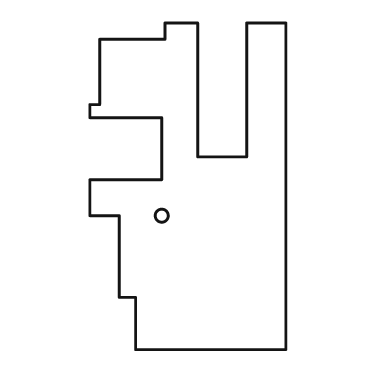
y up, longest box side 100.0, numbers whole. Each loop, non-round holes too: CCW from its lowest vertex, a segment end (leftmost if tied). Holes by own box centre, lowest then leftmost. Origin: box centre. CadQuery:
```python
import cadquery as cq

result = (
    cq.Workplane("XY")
    .moveTo(-16.0, -50.0)
    .lineTo(30.0, -50.0)
    .lineTo(30.0, 50.0)
    .lineTo(18.0, 50.0)
    .lineTo(18.0, 9.0)
    .lineTo(3.0, 9.0)
    .lineTo(3.0, 50.0)
    .lineTo(-7.0, 50.0)
    .lineTo(-7.0, 45.0)
    .lineTo(-27.0, 45.0)
    .lineTo(-27.0, 25.0)
    .lineTo(-30.0, 25.0)
    .lineTo(-30.0, 21.0)
    .lineTo(-8.0, 21.0)
    .lineTo(-8.0, 2.0)
    .lineTo(-30.0, 2.0)
    .lineTo(-30.0, -9.0)
    .lineTo(-21.0, -9.0)
    .lineTo(-21.0, -34.0)
    .lineTo(-16.0, -34.0)
    .close()
    .moveTo(-8.0, -9.0)
    .circle(2.0)
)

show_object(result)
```